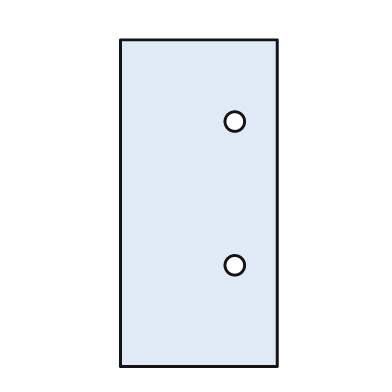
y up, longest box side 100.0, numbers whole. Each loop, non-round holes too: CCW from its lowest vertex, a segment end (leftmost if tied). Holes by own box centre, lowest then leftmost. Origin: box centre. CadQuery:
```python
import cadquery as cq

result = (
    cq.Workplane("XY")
    .moveTo(-24.0, -50.0)
    .lineTo(24.0, -50.0)
    .lineTo(24.0, 50.0)
    .lineTo(-24.0, 50.0)
    .close()
    .moveTo(11.0, -19.0)
    .circle(3.0)
    .moveTo(11.0, 25.0)
    .circle(3.0)
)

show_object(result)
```